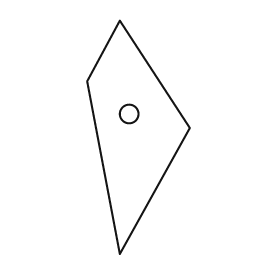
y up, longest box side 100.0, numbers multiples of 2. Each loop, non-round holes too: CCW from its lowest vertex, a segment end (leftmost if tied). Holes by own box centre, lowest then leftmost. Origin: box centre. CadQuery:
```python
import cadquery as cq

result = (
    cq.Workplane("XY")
    .moveTo(-8.0, -50.0)
    .lineTo(22.0, 4.0)
    .lineTo(-8.0, 50.0)
    .lineTo(-22.0, 24.0)
    .close()
    .moveTo(-4.0, 10.0)
    .circle(4.0)
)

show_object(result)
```